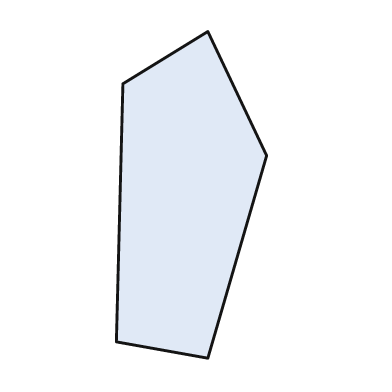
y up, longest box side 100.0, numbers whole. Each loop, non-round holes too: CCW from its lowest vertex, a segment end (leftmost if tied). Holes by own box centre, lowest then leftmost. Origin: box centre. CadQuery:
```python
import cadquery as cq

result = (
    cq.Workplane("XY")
    .moveTo(5.0, -50.0)
    .lineTo(23.0, 12.0)
    .lineTo(5.0, 50.0)
    .lineTo(-21.0, 34.0)
    .lineTo(-23.0, -45.0)
    .close()
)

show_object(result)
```